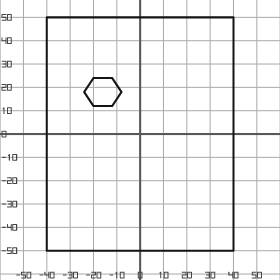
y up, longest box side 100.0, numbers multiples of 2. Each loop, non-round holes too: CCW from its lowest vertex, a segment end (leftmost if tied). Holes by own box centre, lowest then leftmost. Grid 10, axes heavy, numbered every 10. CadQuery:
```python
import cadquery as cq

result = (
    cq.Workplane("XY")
    .moveTo(-40.0, -50.0)
    .lineTo(40.0, -50.0)
    .lineTo(40.0, 50.0)
    .lineTo(-40.0, 50.0)
    .close()
    .moveTo(-20.0, 12.0)
    .lineTo(-12.0, 12.0)
    .lineTo(-8.0, 18.0)
    .lineTo(-12.0, 24.0)
    .lineTo(-20.0, 24.0)
    .lineTo(-24.0, 18.0)
    .close()
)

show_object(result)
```